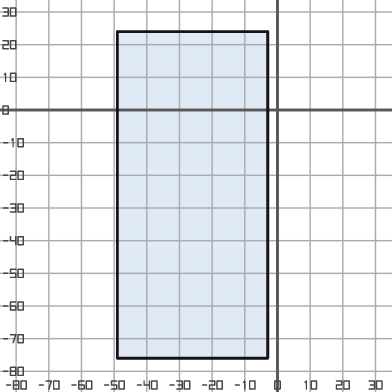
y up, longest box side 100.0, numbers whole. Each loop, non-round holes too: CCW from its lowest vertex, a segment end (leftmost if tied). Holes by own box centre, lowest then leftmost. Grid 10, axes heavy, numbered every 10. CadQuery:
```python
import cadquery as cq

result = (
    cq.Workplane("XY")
    .moveTo(-49.0, -76.0)
    .lineTo(-3.0, -76.0)
    .lineTo(-3.0, 24.0)
    .lineTo(-49.0, 24.0)
    .close()
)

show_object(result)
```